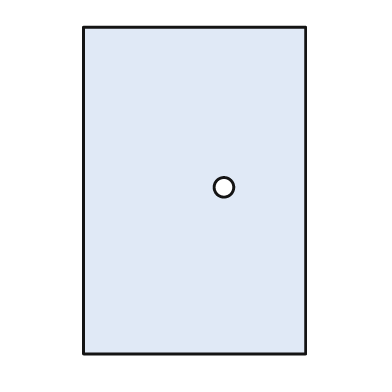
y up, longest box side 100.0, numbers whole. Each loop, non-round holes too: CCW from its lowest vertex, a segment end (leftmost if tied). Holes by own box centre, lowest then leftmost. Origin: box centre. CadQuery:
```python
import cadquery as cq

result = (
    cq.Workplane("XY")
    .moveTo(-34.0, -50.0)
    .lineTo(34.0, -50.0)
    .lineTo(34.0, 50.0)
    .lineTo(-34.0, 50.0)
    .close()
    .moveTo(9.0, 1.0)
    .circle(3.0)
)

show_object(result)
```